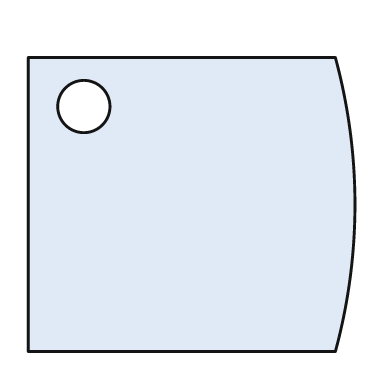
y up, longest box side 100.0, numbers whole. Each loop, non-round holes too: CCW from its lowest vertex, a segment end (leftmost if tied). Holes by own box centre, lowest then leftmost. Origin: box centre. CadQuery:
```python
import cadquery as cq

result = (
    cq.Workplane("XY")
    .moveTo(-50.0, -45.0)
    .lineTo(44.0, -45.0)
    .threePointArc((50.0, 0.0), (44.0, 45.0))
    .lineTo(-50.0, 45.0)
    .close()
    .moveTo(-33.0, 30.0)
    .circle(8.0)
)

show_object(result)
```